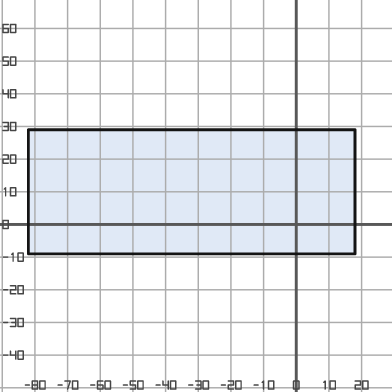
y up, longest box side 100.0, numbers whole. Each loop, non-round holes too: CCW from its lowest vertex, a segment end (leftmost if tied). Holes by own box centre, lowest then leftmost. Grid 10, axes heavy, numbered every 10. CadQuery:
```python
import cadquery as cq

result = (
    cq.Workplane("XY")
    .moveTo(-82.0, -9.0)
    .lineTo(18.0, -9.0)
    .lineTo(18.0, 29.0)
    .lineTo(-82.0, 29.0)
    .close()
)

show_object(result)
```